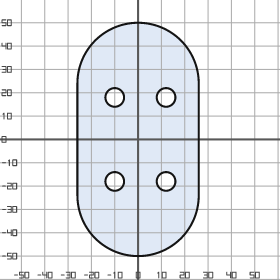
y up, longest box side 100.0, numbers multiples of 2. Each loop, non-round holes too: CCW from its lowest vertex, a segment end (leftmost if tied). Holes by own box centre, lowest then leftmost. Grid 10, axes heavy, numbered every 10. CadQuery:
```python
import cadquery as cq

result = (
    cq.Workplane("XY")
    .moveTo(-26.0, -24.0)
    .threePointArc((0.0, -50.0), (26.0, -24.0))
    .lineTo(26.0, 24.0)
    .threePointArc((0.0, 50.0), (-26.0, 24.0))
    .close()
    .moveTo(-10.0, -18.0)
    .circle(4.0)
    .moveTo(12.0, -18.0)
    .circle(4.0)
    .moveTo(-10.0, 18.0)
    .circle(4.0)
    .moveTo(12.0, 18.0)
    .circle(4.0)
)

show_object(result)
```